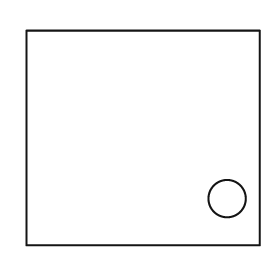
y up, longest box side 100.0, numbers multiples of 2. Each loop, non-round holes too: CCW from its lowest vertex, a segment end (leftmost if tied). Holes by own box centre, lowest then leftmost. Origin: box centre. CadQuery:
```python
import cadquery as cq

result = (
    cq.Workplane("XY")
    .moveTo(-50.0, -46.0)
    .lineTo(50.0, -46.0)
    .lineTo(50.0, 46.0)
    .lineTo(-50.0, 46.0)
    .close()
    .moveTo(36.0, -26.0)
    .circle(8.0)
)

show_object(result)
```